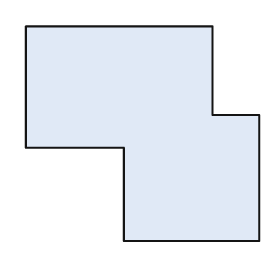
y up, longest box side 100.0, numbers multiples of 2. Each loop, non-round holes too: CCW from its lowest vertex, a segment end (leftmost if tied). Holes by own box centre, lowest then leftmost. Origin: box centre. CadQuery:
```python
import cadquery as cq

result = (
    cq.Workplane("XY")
    .moveTo(-8.0, -46.0)
    .lineTo(50.0, -46.0)
    .lineTo(50.0, 8.0)
    .lineTo(30.0, 8.0)
    .lineTo(30.0, 46.0)
    .lineTo(-50.0, 46.0)
    .lineTo(-50.0, -6.0)
    .lineTo(-8.0, -6.0)
    .close()
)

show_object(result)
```